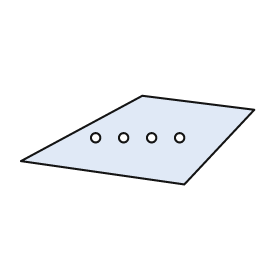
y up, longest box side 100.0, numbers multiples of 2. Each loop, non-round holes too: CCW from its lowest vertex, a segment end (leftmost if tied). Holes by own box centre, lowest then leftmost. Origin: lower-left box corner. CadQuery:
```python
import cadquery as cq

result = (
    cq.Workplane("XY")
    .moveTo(70.0, 0.0)
    .lineTo(100.0, 32.0)
    .lineTo(52.0, 38.0)
    .lineTo(0.0, 10.0)
    .close()
    .moveTo(32.0, 20.0)
    .circle(2.0)
    .moveTo(44.0, 20.0)
    .circle(2.0)
    .moveTo(56.0, 20.0)
    .circle(2.0)
    .moveTo(68.0, 20.0)
    .circle(2.0)
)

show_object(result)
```